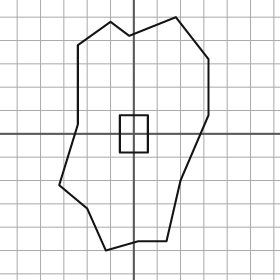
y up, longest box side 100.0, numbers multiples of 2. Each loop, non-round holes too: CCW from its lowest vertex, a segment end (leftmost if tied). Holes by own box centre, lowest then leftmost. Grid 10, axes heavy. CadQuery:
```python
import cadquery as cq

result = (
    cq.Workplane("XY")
    .moveTo(-12.0, -50.0)
    .lineTo(2.0, -46.0)
    .lineTo(14.0, -46.0)
    .lineTo(20.0, -20.0)
    .lineTo(32.0, 8.0)
    .lineTo(32.0, 32.0)
    .lineTo(18.0, 50.0)
    .lineTo(-2.0, 42.0)
    .lineTo(-10.0, 48.0)
    .lineTo(-24.0, 38.0)
    .lineTo(-24.0, 4.0)
    .lineTo(-32.0, -22.0)
    .lineTo(-20.0, -32.0)
    .close()
    .moveTo(-6.0, -8.0)
    .lineTo(6.0, -8.0)
    .lineTo(6.0, 8.0)
    .lineTo(-6.0, 8.0)
    .close()
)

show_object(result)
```